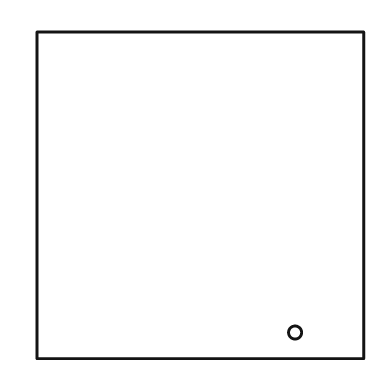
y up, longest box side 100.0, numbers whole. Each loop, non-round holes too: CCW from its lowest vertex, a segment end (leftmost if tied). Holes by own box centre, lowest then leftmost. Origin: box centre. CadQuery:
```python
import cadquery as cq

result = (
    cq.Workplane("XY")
    .moveTo(-50.0, -50.0)
    .lineTo(50.0, -50.0)
    .lineTo(50.0, 50.0)
    .lineTo(-50.0, 50.0)
    .close()
    .moveTo(29.0, -42.0)
    .circle(2.0)
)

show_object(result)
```